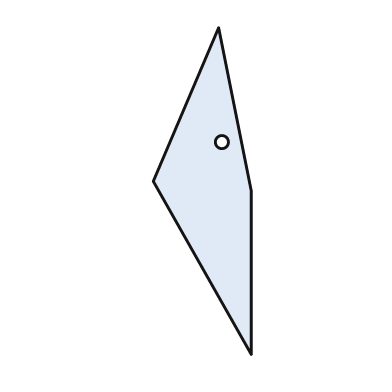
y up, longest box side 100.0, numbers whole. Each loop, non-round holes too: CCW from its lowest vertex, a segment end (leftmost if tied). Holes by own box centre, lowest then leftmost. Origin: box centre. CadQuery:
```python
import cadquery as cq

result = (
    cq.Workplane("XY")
    .moveTo(15.0, -50.0)
    .lineTo(15.0, 0.0)
    .lineTo(5.0, 50.0)
    .lineTo(-15.0, 3.0)
    .close()
    .moveTo(6.0, 15.0)
    .circle(2.0)
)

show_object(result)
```